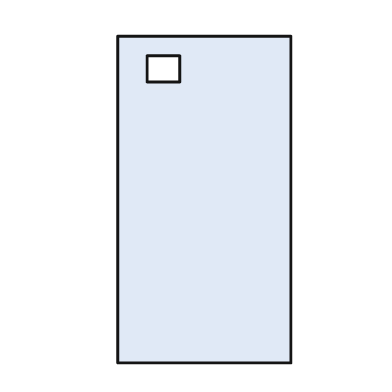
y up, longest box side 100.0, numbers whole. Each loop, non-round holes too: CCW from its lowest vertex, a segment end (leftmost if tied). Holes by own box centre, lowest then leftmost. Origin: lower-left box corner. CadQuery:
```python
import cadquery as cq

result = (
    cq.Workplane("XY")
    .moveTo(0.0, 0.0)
    .lineTo(53.0, 0.0)
    .lineTo(53.0, 100.0)
    .lineTo(0.0, 100.0)
    .close()
    .moveTo(9.0, 86.0)
    .lineTo(19.0, 86.0)
    .lineTo(19.0, 94.0)
    .lineTo(9.0, 94.0)
    .close()
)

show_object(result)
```